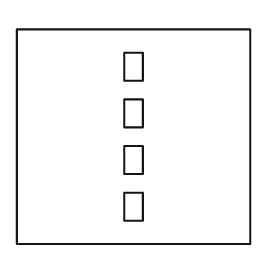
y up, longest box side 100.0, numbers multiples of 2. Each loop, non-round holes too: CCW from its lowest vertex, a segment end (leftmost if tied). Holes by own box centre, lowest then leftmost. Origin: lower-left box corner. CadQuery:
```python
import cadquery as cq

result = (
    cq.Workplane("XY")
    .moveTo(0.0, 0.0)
    .lineTo(100.0, 0.0)
    .lineTo(100.0, 92.0)
    .lineTo(0.0, 92.0)
    .close()
    .moveTo(46.0, 10.0)
    .lineTo(54.0, 10.0)
    .lineTo(54.0, 22.0)
    .lineTo(46.0, 22.0)
    .close()
    .moveTo(46.0, 30.0)
    .lineTo(54.0, 30.0)
    .lineTo(54.0, 42.0)
    .lineTo(46.0, 42.0)
    .close()
    .moveTo(46.0, 50.0)
    .lineTo(54.0, 50.0)
    .lineTo(54.0, 62.0)
    .lineTo(46.0, 62.0)
    .close()
    .moveTo(46.0, 70.0)
    .lineTo(54.0, 70.0)
    .lineTo(54.0, 82.0)
    .lineTo(46.0, 82.0)
    .close()
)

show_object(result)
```